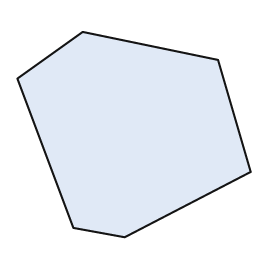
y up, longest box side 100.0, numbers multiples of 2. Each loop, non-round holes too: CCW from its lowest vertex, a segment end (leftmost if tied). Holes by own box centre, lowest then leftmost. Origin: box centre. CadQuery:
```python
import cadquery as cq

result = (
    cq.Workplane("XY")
    .moveTo(-4.0, -44.0)
    .lineTo(50.0, -16.0)
    .lineTo(36.0, 32.0)
    .lineTo(-22.0, 44.0)
    .lineTo(-50.0, 24.0)
    .lineTo(-26.0, -40.0)
    .close()
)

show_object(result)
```